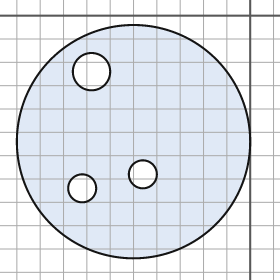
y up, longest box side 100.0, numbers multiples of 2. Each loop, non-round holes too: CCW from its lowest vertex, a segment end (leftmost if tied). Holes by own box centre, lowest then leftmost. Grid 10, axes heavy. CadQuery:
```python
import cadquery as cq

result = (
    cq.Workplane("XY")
    .moveTo(-50.0, -54.0)
    .circle(50.0)
    .moveTo(-72.0, -74.0)
    .circle(6.0)
    .moveTo(-46.0, -68.0)
    .circle(6.0)
    .moveTo(-68.0, -24.0)
    .circle(8.0)
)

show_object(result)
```